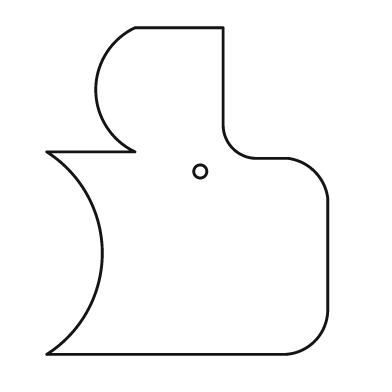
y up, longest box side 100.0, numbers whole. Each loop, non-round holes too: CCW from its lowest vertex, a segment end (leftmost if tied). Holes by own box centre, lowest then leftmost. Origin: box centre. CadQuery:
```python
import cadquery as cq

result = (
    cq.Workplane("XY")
    .moveTo(-43.0, -50.0)
    .lineTo(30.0, -50.0)
    .threePointArc((39.0, -46.0), (43.0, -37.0))
    .lineTo(43.0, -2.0)
    .threePointArc((39.0, 6.0), (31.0, 10.0))
    .lineTo(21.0, 10.0)
    .threePointArc((14.0, 13.0), (11.0, 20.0))
    .lineTo(11.0, 50.0)
    .lineTo(-16.0, 50.0)
    .threePointArc((-28.0, 31.0), (-16.0, 12.0))
    .lineTo(-43.0, 12.0)
    .threePointArc((-26.0, -19.0), (-43.0, -50.0))
    .close()
    .moveTo(4.0, 6.0)
    .circle(2.0)
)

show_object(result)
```